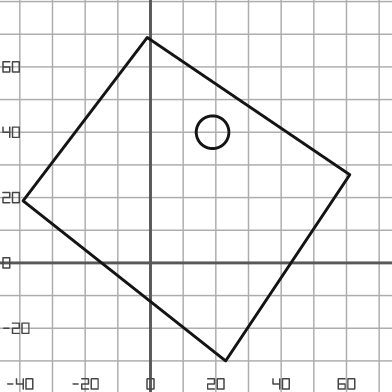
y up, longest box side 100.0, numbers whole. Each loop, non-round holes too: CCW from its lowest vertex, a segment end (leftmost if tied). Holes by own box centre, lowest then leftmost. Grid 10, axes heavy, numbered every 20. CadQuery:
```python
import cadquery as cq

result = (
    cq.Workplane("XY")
    .moveTo(23.0, -30.0)
    .lineTo(61.0, 27.0)
    .lineTo(-1.0, 69.0)
    .lineTo(-39.0, 19.0)
    .close()
    .moveTo(19.0, 40.0)
    .circle(5.0)
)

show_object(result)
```